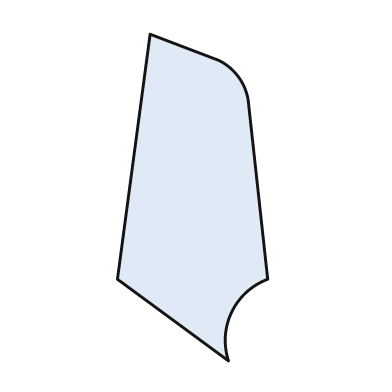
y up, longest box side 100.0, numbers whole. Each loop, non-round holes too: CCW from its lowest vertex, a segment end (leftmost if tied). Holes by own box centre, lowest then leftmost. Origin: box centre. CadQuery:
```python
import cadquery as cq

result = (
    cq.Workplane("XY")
    .moveTo(11.0, -50.0)
    .threePointArc((12.0, -35.0), (23.0, -25.0))
    .lineTo(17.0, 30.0)
    .threePointArc((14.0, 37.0), (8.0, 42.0))
    .lineTo(-13.0, 50.0)
    .lineTo(-23.0, -25.0)
    .close()
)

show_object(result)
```